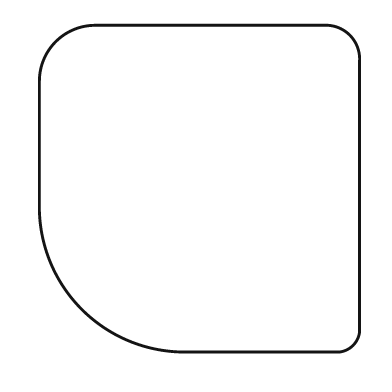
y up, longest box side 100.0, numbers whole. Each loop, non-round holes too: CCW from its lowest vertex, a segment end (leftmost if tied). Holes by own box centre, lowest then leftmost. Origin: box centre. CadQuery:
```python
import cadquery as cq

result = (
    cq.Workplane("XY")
    .moveTo(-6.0, -50.0)
    .lineTo(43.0, -50.0)
    .threePointArc((47.0, -48.0), (49.0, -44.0))
    .lineTo(49.0, 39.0)
    .threePointArc((46.0, 47.0), (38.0, 50.0))
    .lineTo(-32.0, 50.0)
    .threePointArc((-44.0, 45.0), (-49.0, 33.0))
    .lineTo(-49.0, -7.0)
    .threePointArc((-36.0, -37.0), (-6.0, -50.0))
    .close()
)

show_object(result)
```